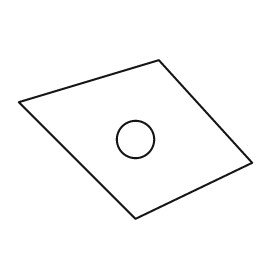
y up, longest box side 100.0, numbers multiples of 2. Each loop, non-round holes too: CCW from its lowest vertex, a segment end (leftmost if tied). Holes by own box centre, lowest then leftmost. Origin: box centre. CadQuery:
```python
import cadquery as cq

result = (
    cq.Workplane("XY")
    .moveTo(0.0, -34.0)
    .lineTo(50.0, -10.0)
    .lineTo(10.0, 34.0)
    .lineTo(-50.0, 16.0)
    .close()
    .moveTo(0.0, 0.0)
    .circle(8.0)
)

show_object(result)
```